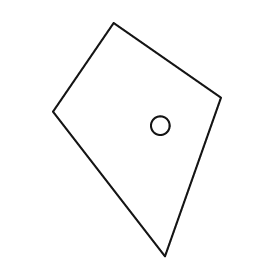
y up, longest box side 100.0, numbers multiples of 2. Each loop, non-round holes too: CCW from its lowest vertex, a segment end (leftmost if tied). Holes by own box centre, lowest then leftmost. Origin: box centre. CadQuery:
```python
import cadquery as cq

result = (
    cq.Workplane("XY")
    .moveTo(12.0, -50.0)
    .lineTo(36.0, 18.0)
    .lineTo(-10.0, 50.0)
    .lineTo(-36.0, 12.0)
    .close()
    .moveTo(10.0, 6.0)
    .circle(4.0)
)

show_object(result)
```